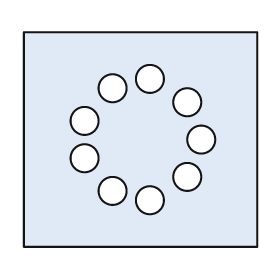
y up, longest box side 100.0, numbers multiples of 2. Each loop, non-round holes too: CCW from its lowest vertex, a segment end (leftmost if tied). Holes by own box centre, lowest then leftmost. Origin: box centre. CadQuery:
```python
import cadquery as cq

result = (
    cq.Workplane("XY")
    .moveTo(-50.0, -46.0)
    .lineTo(50.0, -46.0)
    .lineTo(50.0, 46.0)
    .lineTo(-50.0, 46.0)
    .close()
    .moveTo(4.0, -26.0)
    .circle(6.0)
    .moveTo(-12.0, -22.0)
    .circle(6.0)
    .moveTo(20.0, -16.0)
    .circle(6.0)
    .moveTo(-24.0, -8.0)
    .circle(6.0)
    .moveTo(26.0, 0.0)
    .circle(6.0)
    .moveTo(-24.0, 8.0)
    .circle(6.0)
    .moveTo(20.0, 16.0)
    .circle(6.0)
    .moveTo(-12.0, 22.0)
    .circle(6.0)
    .moveTo(4.0, 26.0)
    .circle(6.0)
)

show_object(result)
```